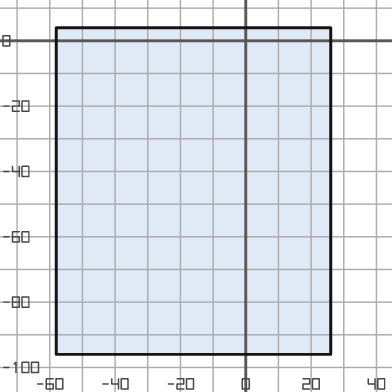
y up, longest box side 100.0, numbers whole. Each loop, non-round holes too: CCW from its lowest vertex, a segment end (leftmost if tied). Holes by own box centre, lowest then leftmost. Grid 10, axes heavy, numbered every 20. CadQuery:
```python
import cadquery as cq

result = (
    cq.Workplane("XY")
    .moveTo(-58.0, -96.0)
    .lineTo(26.0, -96.0)
    .lineTo(26.0, 4.0)
    .lineTo(-58.0, 4.0)
    .close()
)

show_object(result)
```